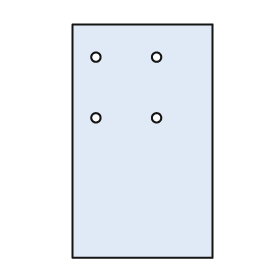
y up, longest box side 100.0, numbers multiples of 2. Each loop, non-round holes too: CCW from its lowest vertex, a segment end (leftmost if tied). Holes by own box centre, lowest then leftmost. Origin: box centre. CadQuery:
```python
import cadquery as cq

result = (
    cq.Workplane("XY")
    .moveTo(-30.0, -50.0)
    .lineTo(30.0, -50.0)
    .lineTo(30.0, 50.0)
    .lineTo(-30.0, 50.0)
    .close()
    .moveTo(-20.0, 10.0)
    .circle(2.0)
    .moveTo(6.0, 10.0)
    .circle(2.0)
    .moveTo(-20.0, 36.0)
    .circle(2.0)
    .moveTo(6.0, 36.0)
    .circle(2.0)
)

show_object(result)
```